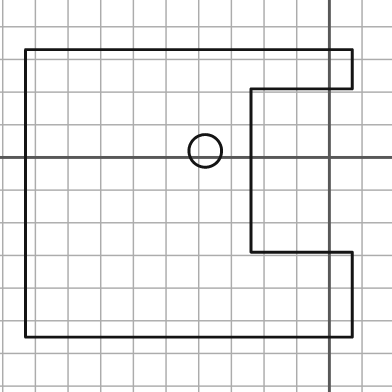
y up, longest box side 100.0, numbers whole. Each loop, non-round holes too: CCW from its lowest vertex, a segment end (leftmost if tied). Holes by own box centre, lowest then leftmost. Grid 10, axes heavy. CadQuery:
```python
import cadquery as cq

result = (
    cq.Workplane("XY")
    .moveTo(-93.0, -55.0)
    .lineTo(7.0, -55.0)
    .lineTo(7.0, -29.0)
    .lineTo(-24.0, -29.0)
    .lineTo(-24.0, 21.0)
    .lineTo(7.0, 21.0)
    .lineTo(7.0, 33.0)
    .lineTo(-93.0, 33.0)
    .close()
    .moveTo(-38.0, 2.0)
    .circle(5.0)
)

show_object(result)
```